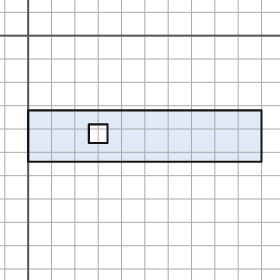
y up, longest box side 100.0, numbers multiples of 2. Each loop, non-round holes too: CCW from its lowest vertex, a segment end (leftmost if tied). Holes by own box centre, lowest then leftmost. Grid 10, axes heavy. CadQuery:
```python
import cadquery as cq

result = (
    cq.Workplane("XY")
    .moveTo(0.0, -54.0)
    .lineTo(100.0, -54.0)
    .lineTo(100.0, -32.0)
    .lineTo(0.0, -32.0)
    .close()
    .moveTo(26.0, -46.0)
    .lineTo(34.0, -46.0)
    .lineTo(34.0, -38.0)
    .lineTo(26.0, -38.0)
    .close()
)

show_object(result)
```